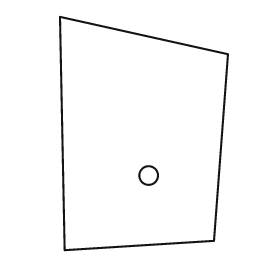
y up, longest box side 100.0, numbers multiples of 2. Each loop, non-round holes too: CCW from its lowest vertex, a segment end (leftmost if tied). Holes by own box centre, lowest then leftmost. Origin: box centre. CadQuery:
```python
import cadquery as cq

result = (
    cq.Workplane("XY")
    .moveTo(-34.0, -50.0)
    .lineTo(30.0, -46.0)
    .lineTo(36.0, 34.0)
    .lineTo(-36.0, 50.0)
    .close()
    .moveTo(2.0, -18.0)
    .circle(4.0)
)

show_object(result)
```